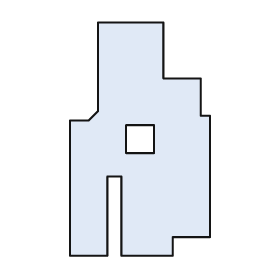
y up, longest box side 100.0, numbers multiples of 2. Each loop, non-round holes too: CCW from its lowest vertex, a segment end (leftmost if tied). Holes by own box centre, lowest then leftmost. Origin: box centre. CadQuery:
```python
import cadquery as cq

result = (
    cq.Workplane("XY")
    .moveTo(-30.0, -50.0)
    .lineTo(-14.0, -50.0)
    .lineTo(-14.0, -16.0)
    .lineTo(-8.0, -16.0)
    .lineTo(-8.0, -50.0)
    .lineTo(14.0, -50.0)
    .lineTo(14.0, -42.0)
    .lineTo(30.0, -42.0)
    .lineTo(30.0, 10.0)
    .lineTo(26.0, 10.0)
    .lineTo(26.0, 26.0)
    .lineTo(10.0, 26.0)
    .lineTo(10.0, 50.0)
    .lineTo(-18.0, 50.0)
    .lineTo(-18.0, 12.0)
    .lineTo(-22.0, 8.0)
    .lineTo(-30.0, 8.0)
    .close()
    .moveTo(-6.0, -6.0)
    .lineTo(6.0, -6.0)
    .lineTo(6.0, 6.0)
    .lineTo(-6.0, 6.0)
    .close()
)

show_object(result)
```